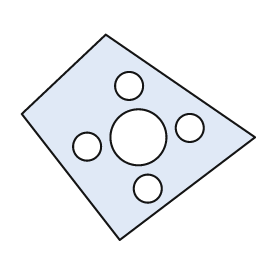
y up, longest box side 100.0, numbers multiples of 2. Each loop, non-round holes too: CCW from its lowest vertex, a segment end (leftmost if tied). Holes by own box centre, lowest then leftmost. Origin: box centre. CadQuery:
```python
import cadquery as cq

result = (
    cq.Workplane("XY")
    .moveTo(-8.0, -44.0)
    .lineTo(50.0, 0.0)
    .lineTo(-14.0, 44.0)
    .lineTo(-50.0, 10.0)
    .close()
    .moveTo(4.0, -22.0)
    .circle(6.0)
    .moveTo(-22.0, -4.0)
    .circle(6.0)
    .moveTo(0.0, 0.0)
    .circle(12.0)
    .moveTo(22.0, 4.0)
    .circle(6.0)
    .moveTo(-4.0, 22.0)
    .circle(6.0)
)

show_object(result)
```